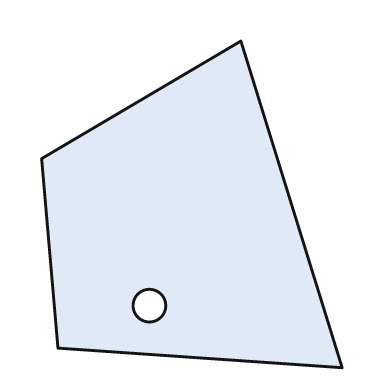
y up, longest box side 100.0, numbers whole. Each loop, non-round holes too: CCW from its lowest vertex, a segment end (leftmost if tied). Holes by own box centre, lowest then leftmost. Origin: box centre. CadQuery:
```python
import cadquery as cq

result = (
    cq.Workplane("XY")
    .moveTo(46.0, -50.0)
    .lineTo(15.0, 50.0)
    .lineTo(-46.0, 14.0)
    .lineTo(-41.0, -44.0)
    .close()
    .moveTo(-13.0, -31.0)
    .circle(5.0)
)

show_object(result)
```